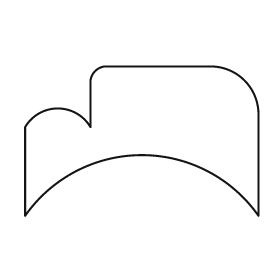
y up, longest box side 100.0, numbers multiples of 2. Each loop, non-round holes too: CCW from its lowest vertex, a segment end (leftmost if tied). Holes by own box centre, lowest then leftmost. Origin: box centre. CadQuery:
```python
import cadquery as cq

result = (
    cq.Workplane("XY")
    .moveTo(-50.0, -32.0)
    .threePointArc((0.0, -6.0), (50.0, -32.0))
    .lineTo(50.0, 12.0)
    .threePointArc((44.0, 26.0), (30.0, 32.0))
    .lineTo(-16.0, 32.0)
    .threePointArc((-20.0, 30.0), (-22.0, 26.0))
    .lineTo(-22.0, 6.0)
    .threePointArc((-36.0, 14.0), (-50.0, 6.0))
    .close()
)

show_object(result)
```